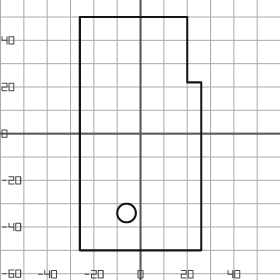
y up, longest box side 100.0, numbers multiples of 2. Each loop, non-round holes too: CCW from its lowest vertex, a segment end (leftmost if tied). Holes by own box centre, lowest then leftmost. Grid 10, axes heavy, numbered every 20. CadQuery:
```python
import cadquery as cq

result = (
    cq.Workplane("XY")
    .moveTo(-26.0, -50.0)
    .lineTo(26.0, -50.0)
    .lineTo(26.0, 22.0)
    .lineTo(20.0, 22.0)
    .lineTo(20.0, 50.0)
    .lineTo(-26.0, 50.0)
    .close()
    .moveTo(-6.0, -34.0)
    .circle(4.0)
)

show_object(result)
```